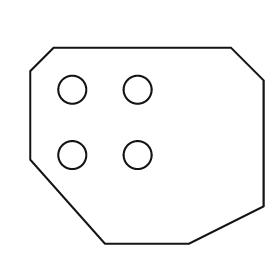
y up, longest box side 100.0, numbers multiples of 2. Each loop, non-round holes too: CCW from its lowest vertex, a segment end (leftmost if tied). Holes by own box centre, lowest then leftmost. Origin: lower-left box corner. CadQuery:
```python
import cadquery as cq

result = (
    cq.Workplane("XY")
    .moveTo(32.0, 0.0)
    .lineTo(68.0, 0.0)
    .lineTo(100.0, 16.0)
    .lineTo(100.0, 70.0)
    .lineTo(86.0, 84.0)
    .lineTo(10.0, 84.0)
    .lineTo(0.0, 74.0)
    .lineTo(0.0, 36.0)
    .close()
    .moveTo(18.0, 38.0)
    .circle(6.0)
    .moveTo(46.0, 38.0)
    .circle(6.0)
    .moveTo(18.0, 66.0)
    .circle(6.0)
    .moveTo(46.0, 66.0)
    .circle(6.0)
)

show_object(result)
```